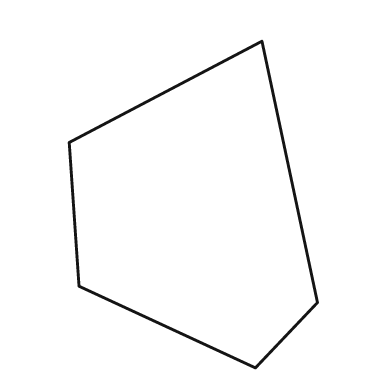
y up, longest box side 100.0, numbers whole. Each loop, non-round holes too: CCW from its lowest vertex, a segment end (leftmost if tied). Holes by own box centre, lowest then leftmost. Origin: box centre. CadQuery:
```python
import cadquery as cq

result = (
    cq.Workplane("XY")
    .moveTo(19.0, -50.0)
    .lineTo(38.0, -30.0)
    .lineTo(21.0, 50.0)
    .lineTo(-38.0, 19.0)
    .lineTo(-35.0, -25.0)
    .close()
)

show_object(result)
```